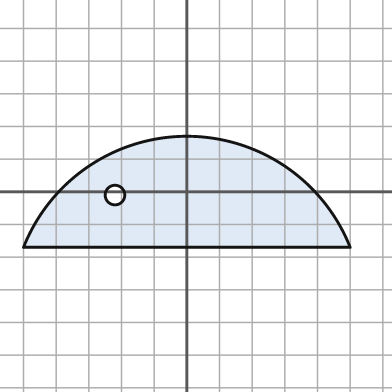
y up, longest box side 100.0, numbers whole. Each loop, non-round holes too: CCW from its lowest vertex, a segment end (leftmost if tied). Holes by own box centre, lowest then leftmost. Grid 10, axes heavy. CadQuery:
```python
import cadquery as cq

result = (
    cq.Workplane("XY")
    .moveTo(-50.0, -17.0)
    .lineTo(50.0, -17.0)
    .threePointArc((0.0, 17.0), (-50.0, -17.0))
    .close()
    .moveTo(-22.0, -1.0)
    .circle(3.0)
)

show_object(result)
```